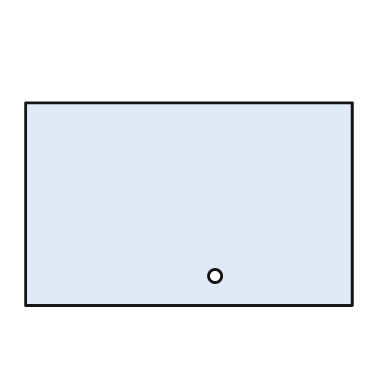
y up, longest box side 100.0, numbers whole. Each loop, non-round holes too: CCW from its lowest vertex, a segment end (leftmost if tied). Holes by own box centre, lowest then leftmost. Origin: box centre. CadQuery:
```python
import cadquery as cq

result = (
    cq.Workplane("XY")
    .moveTo(-50.0, -31.0)
    .lineTo(50.0, -31.0)
    .lineTo(50.0, 31.0)
    .lineTo(-50.0, 31.0)
    .close()
    .moveTo(8.0, -22.0)
    .circle(2.0)
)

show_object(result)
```